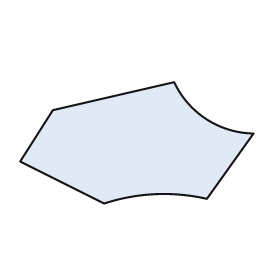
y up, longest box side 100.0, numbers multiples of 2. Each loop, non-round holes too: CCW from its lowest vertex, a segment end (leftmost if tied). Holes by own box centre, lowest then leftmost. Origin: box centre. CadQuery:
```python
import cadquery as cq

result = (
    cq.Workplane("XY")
    .moveTo(-14.0, -26.0)
    .threePointArc((8.0, -22.0), (30.0, -24.0))
    .lineTo(50.0, 4.0)
    .threePointArc((30.0, 10.0), (16.0, 26.0))
    .lineTo(-36.0, 14.0)
    .lineTo(-50.0, -8.0)
    .close()
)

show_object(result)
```